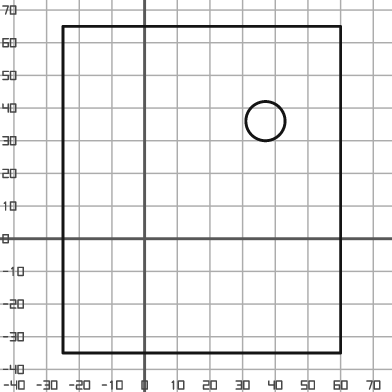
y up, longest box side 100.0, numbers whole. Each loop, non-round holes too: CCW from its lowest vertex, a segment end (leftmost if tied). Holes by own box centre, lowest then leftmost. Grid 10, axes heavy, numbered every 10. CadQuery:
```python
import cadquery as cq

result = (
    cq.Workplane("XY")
    .moveTo(-25.0, -35.0)
    .lineTo(60.0, -35.0)
    .lineTo(60.0, 65.0)
    .lineTo(-25.0, 65.0)
    .close()
    .moveTo(37.0, 36.0)
    .circle(6.0)
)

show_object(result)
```